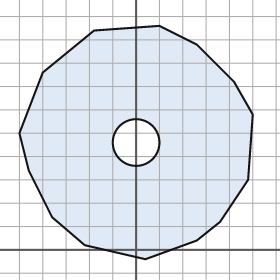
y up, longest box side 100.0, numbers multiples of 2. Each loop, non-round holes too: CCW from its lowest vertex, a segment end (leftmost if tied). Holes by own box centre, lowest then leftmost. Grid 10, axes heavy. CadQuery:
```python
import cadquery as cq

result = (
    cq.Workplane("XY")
    .moveTo(4.0, -4.0)
    .lineTo(26.0, 4.0)
    .lineTo(36.0, 12.0)
    .lineTo(48.0, 30.0)
    .lineTo(50.0, 58.0)
    .lineTo(42.0, 72.0)
    .lineTo(26.0, 88.0)
    .lineTo(10.0, 96.0)
    .lineTo(-18.0, 94.0)
    .lineTo(-40.0, 76.0)
    .lineTo(-50.0, 50.0)
    .lineTo(-46.0, 34.0)
    .lineTo(-36.0, 14.0)
    .lineTo(-22.0, 2.0)
    .close()
    .moveTo(0.0, 46.0)
    .circle(10.0)
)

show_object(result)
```